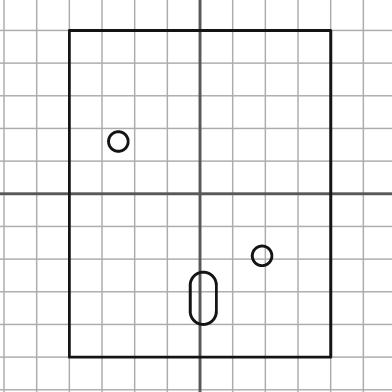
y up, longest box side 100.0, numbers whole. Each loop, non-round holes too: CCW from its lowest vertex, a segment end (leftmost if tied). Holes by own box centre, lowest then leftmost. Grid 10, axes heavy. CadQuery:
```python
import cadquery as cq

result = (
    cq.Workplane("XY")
    .moveTo(-40.0, -50.0)
    .lineTo(40.0, -50.0)
    .lineTo(40.0, 50.0)
    .lineTo(-40.0, 50.0)
    .close()
    .moveTo(-3.0, -36.0)
    .threePointArc((1.0, -40.0), (5.0, -36.0))
    .lineTo(5.0, -28.0)
    .threePointArc((1.0, -24.0), (-3.0, -28.0))
    .close()
    .moveTo(19.0, -19.0)
    .circle(3.0)
    .moveTo(-25.0, 16.0)
    .circle(3.0)
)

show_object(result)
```